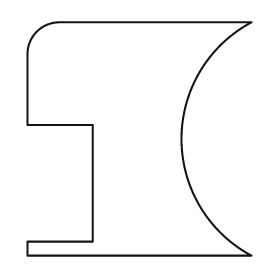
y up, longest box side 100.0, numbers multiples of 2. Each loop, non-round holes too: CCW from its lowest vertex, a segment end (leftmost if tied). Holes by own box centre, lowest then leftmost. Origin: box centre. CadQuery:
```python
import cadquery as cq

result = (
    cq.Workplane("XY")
    .moveTo(-48.0, -50.0)
    .lineTo(48.0, -50.0)
    .threePointArc((18.0, 0.0), (48.0, 50.0))
    .lineTo(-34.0, 50.0)
    .threePointArc((-44.0, 46.0), (-48.0, 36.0))
    .lineTo(-48.0, 6.0)
    .lineTo(-20.0, 6.0)
    .lineTo(-20.0, -44.0)
    .lineTo(-48.0, -44.0)
    .close()
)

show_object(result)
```